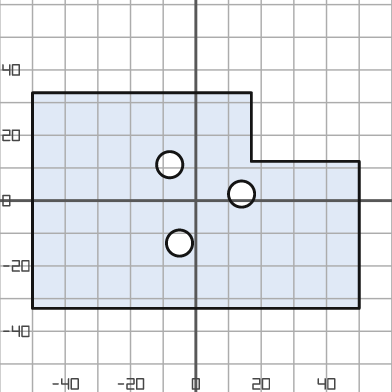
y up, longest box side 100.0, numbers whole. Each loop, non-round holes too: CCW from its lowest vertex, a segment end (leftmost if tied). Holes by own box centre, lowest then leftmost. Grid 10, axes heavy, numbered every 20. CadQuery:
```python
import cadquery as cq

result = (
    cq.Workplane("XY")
    .moveTo(-50.0, -33.0)
    .lineTo(50.0, -33.0)
    .lineTo(50.0, 12.0)
    .lineTo(17.0, 12.0)
    .lineTo(17.0, 33.0)
    .lineTo(-50.0, 33.0)
    .close()
    .moveTo(-5.0, -13.0)
    .circle(4.0)
    .moveTo(14.0, 2.0)
    .circle(4.0)
    .moveTo(-8.0, 11.0)
    .circle(4.0)
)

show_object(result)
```